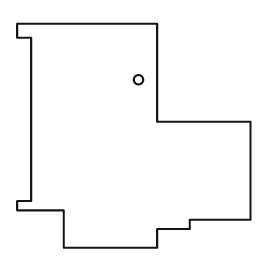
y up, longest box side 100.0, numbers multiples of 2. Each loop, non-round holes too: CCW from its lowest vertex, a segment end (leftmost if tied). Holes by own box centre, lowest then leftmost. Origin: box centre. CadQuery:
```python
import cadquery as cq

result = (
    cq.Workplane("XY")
    .moveTo(-30.0, -48.0)
    .lineTo(10.0, -48.0)
    .lineTo(10.0, -40.0)
    .lineTo(24.0, -40.0)
    .lineTo(24.0, -36.0)
    .lineTo(50.0, -36.0)
    .lineTo(50.0, 6.0)
    .lineTo(10.0, 6.0)
    .lineTo(10.0, 48.0)
    .lineTo(-50.0, 48.0)
    .lineTo(-50.0, 42.0)
    .lineTo(-44.0, 42.0)
    .lineTo(-44.0, -28.0)
    .lineTo(-50.0, -28.0)
    .lineTo(-50.0, -32.0)
    .lineTo(-30.0, -32.0)
    .close()
    .moveTo(2.0, 24.0)
    .circle(2.0)
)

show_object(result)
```